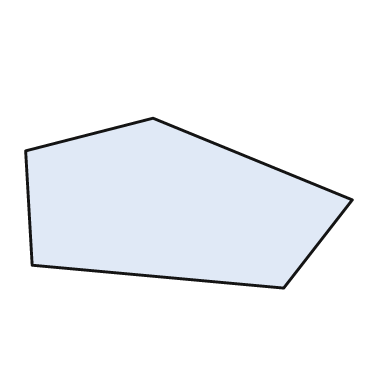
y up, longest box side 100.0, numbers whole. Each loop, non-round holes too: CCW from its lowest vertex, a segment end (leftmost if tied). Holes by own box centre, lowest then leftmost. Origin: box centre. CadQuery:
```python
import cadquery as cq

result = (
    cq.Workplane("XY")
    .moveTo(29.0, -26.0)
    .lineTo(50.0, 1.0)
    .lineTo(-11.0, 26.0)
    .lineTo(-50.0, 16.0)
    .lineTo(-48.0, -19.0)
    .close()
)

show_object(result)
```